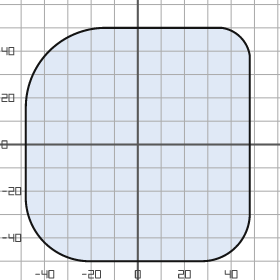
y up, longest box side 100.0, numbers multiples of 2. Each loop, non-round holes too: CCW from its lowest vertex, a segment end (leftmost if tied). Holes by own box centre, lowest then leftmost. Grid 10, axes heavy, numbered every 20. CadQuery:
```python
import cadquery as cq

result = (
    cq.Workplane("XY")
    .moveTo(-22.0, -50.0)
    .lineTo(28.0, -50.0)
    .threePointArc((42.0, -44.0), (48.0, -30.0))
    .lineTo(48.0, 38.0)
    .threePointArc((44.0, 46.0), (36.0, 50.0))
    .lineTo(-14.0, 50.0)
    .threePointArc((-38.0, 40.0), (-48.0, 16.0))
    .lineTo(-48.0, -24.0)
    .threePointArc((-40.0, -42.0), (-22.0, -50.0))
    .close()
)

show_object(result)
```